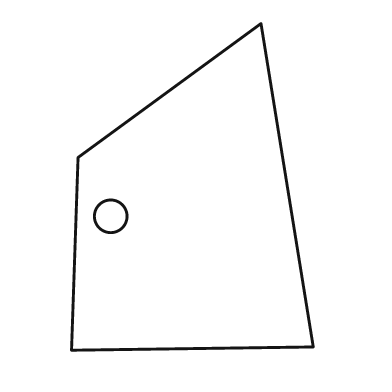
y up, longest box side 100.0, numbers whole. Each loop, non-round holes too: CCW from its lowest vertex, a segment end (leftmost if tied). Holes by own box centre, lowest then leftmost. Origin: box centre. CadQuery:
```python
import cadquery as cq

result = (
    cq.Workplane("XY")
    .moveTo(-37.0, -50.0)
    .lineTo(37.0, -49.0)
    .lineTo(21.0, 50.0)
    .lineTo(-35.0, 9.0)
    .close()
    .moveTo(-25.0, -9.0)
    .circle(5.0)
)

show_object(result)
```